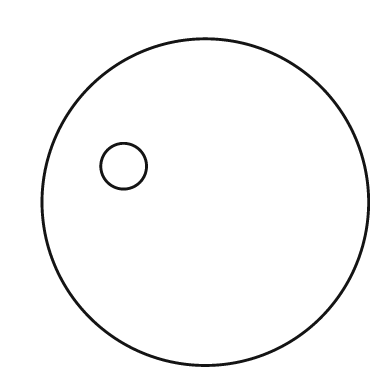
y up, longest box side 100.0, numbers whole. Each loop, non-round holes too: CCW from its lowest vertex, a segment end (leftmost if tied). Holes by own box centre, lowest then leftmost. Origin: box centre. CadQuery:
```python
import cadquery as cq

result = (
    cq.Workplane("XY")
    .moveTo(0.0, 0.0)
    .circle(50.0)
    .moveTo(-25.0, 11.0)
    .circle(7.0)
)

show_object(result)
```